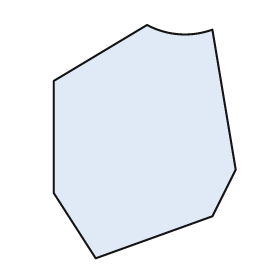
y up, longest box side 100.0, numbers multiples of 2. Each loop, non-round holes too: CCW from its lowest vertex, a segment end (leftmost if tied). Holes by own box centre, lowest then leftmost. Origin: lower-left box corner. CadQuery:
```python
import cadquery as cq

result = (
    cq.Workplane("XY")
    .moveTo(18.0, 0.0)
    .lineTo(68.0, 18.0)
    .lineTo(78.0, 38.0)
    .lineTo(68.0, 98.0)
    .threePointArc((54.0, 96.0), (40.0, 100.0))
    .lineTo(0.0, 76.0)
    .lineTo(0.0, 28.0)
    .close()
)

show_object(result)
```